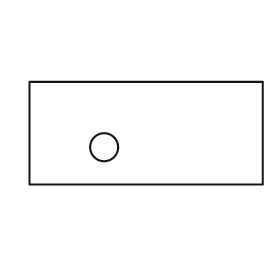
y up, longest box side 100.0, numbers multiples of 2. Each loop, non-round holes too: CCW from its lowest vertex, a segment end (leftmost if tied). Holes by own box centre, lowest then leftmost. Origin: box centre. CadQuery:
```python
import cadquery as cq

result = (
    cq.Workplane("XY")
    .moveTo(-50.0, -22.0)
    .lineTo(50.0, -22.0)
    .lineTo(50.0, 22.0)
    .lineTo(-50.0, 22.0)
    .close()
    .moveTo(-18.0, -6.0)
    .circle(6.0)
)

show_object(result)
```